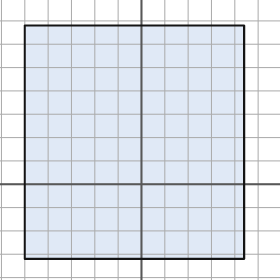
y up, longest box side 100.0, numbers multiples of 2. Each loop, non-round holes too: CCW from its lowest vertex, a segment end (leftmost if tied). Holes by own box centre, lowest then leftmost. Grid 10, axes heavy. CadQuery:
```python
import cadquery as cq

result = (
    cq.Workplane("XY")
    .moveTo(-50.0, -32.0)
    .lineTo(44.0, -32.0)
    .lineTo(44.0, 68.0)
    .lineTo(-50.0, 68.0)
    .close()
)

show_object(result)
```